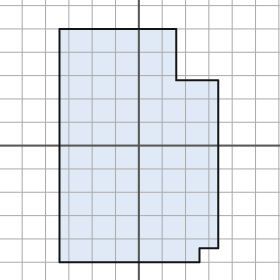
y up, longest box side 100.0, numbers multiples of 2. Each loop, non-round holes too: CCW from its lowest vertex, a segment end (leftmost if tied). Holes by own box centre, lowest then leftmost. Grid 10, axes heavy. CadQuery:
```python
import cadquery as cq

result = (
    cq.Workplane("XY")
    .moveTo(-34.0, -50.0)
    .lineTo(26.0, -50.0)
    .lineTo(26.0, -44.0)
    .lineTo(34.0, -44.0)
    .lineTo(34.0, 28.0)
    .lineTo(16.0, 28.0)
    .lineTo(16.0, 50.0)
    .lineTo(-34.0, 50.0)
    .close()
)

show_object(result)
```